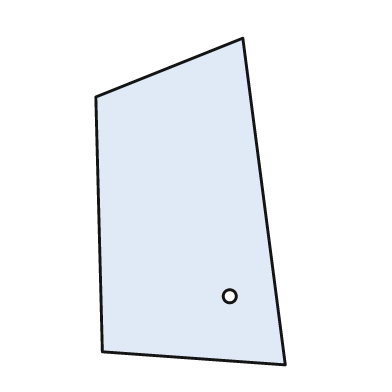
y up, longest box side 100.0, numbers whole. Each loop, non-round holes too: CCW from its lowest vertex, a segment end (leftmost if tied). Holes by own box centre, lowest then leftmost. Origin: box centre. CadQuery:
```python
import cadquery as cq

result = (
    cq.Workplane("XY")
    .moveTo(29.0, -50.0)
    .lineTo(16.0, 50.0)
    .lineTo(-29.0, 32.0)
    .lineTo(-27.0, -46.0)
    .close()
    .moveTo(12.0, -29.0)
    .circle(2.0)
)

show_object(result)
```